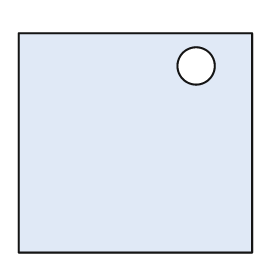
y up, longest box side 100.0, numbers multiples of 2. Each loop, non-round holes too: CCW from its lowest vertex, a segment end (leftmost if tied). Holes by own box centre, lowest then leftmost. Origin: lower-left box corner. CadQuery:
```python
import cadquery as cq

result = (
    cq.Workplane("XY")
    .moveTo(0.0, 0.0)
    .lineTo(100.0, 0.0)
    .lineTo(100.0, 94.0)
    .lineTo(0.0, 94.0)
    .close()
    .moveTo(76.0, 80.0)
    .circle(8.0)
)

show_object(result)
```